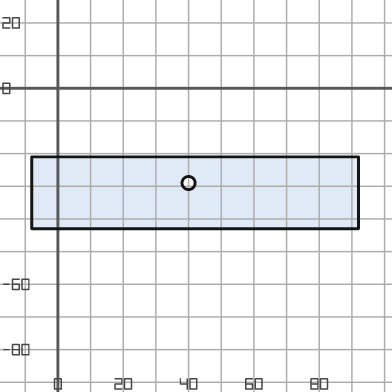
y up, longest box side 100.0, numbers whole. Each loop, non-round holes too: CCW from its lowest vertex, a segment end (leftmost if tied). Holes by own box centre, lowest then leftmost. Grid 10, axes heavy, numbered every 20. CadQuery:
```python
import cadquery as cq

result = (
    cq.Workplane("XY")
    .moveTo(-8.0, -43.0)
    .lineTo(92.0, -43.0)
    .lineTo(92.0, -21.0)
    .lineTo(-8.0, -21.0)
    .close()
    .moveTo(40.0, -29.0)
    .circle(2.0)
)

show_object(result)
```